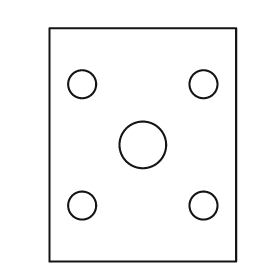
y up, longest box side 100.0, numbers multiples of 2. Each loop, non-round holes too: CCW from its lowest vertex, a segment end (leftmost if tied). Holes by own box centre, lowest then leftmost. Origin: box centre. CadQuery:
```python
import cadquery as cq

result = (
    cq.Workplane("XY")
    .moveTo(-40.0, -50.0)
    .lineTo(40.0, -50.0)
    .lineTo(40.0, 50.0)
    .lineTo(-40.0, 50.0)
    .close()
    .moveTo(-26.0, -26.0)
    .circle(6.0)
    .moveTo(26.0, -26.0)
    .circle(6.0)
    .moveTo(0.0, 0.0)
    .circle(10.0)
    .moveTo(-26.0, 26.0)
    .circle(6.0)
    .moveTo(26.0, 26.0)
    .circle(6.0)
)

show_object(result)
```